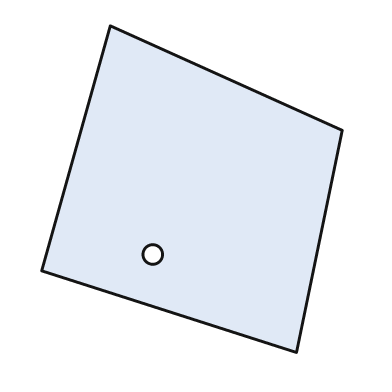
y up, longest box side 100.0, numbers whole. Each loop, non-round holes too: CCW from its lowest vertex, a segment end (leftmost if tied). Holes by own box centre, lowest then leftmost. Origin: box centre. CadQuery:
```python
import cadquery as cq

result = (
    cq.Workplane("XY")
    .moveTo(32.0, -50.0)
    .lineTo(46.0, 18.0)
    .lineTo(-25.0, 50.0)
    .lineTo(-46.0, -25.0)
    .close()
    .moveTo(-12.0, -20.0)
    .circle(3.0)
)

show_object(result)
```